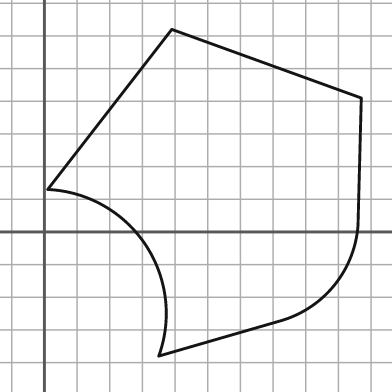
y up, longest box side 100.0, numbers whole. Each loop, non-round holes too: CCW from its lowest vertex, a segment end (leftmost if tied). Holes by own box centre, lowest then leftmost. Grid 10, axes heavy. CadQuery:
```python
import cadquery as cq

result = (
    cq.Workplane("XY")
    .moveTo(35.0, -38.0)
    .lineTo(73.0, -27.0)
    .threePointArc((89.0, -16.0), (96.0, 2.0))
    .lineTo(97.0, 41.0)
    .lineTo(39.0, 62.0)
    .lineTo(1.0, 13.0)
    .threePointArc((31.0, -4.0), (35.0, -38.0))
    .close()
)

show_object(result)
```